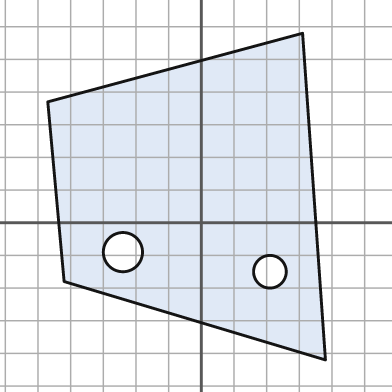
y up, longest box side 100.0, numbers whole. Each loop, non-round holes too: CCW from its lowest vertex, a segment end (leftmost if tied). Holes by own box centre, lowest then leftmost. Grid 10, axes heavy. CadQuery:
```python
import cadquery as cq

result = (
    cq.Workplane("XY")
    .moveTo(38.0, -42.0)
    .lineTo(31.0, 58.0)
    .lineTo(-47.0, 37.0)
    .lineTo(-42.0, -18.0)
    .close()
    .moveTo(21.0, -15.0)
    .circle(5.0)
    .moveTo(-24.0, -9.0)
    .circle(6.0)
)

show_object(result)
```